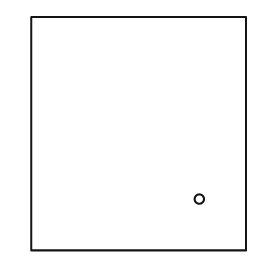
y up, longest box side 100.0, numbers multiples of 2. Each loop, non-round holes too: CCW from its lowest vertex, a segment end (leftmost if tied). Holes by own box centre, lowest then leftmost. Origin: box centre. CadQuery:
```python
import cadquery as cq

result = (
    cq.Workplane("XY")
    .moveTo(-46.0, -50.0)
    .lineTo(46.0, -50.0)
    .lineTo(46.0, 50.0)
    .lineTo(-46.0, 50.0)
    .close()
    .moveTo(26.0, -28.0)
    .circle(2.0)
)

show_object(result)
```